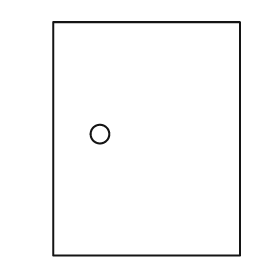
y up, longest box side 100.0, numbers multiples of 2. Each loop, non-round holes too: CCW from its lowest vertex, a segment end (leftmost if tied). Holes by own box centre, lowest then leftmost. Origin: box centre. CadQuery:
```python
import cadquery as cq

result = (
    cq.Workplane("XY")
    .moveTo(-40.0, -50.0)
    .lineTo(40.0, -50.0)
    .lineTo(40.0, 50.0)
    .lineTo(-40.0, 50.0)
    .close()
    .moveTo(-20.0, 2.0)
    .circle(4.0)
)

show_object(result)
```